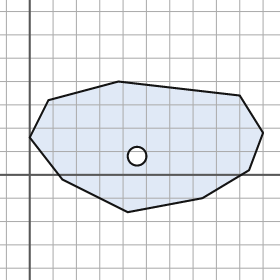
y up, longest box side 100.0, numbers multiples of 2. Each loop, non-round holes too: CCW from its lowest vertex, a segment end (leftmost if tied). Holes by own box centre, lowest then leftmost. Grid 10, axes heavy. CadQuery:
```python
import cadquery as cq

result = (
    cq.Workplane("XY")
    .moveTo(42.0, -16.0)
    .lineTo(74.0, -10.0)
    .lineTo(94.0, 2.0)
    .lineTo(100.0, 18.0)
    .lineTo(90.0, 34.0)
    .lineTo(38.0, 40.0)
    .lineTo(8.0, 32.0)
    .lineTo(0.0, 16.0)
    .lineTo(14.0, -2.0)
    .close()
    .moveTo(46.0, 8.0)
    .circle(4.0)
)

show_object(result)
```